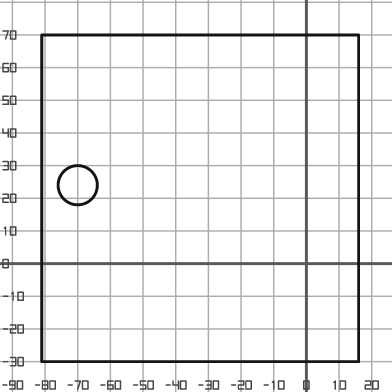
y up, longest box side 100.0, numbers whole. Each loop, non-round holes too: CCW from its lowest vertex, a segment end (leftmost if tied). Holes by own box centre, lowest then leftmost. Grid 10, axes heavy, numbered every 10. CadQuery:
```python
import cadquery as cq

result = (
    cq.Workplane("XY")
    .moveTo(-81.0, -30.0)
    .lineTo(16.0, -30.0)
    .lineTo(16.0, 70.0)
    .lineTo(-81.0, 70.0)
    .close()
    .moveTo(-70.0, 24.0)
    .circle(6.0)
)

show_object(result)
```